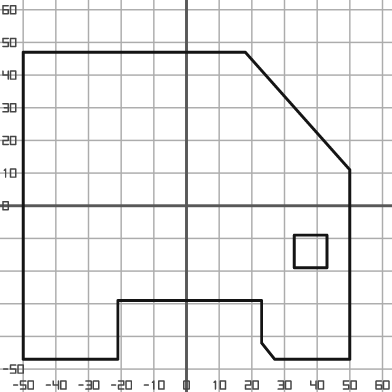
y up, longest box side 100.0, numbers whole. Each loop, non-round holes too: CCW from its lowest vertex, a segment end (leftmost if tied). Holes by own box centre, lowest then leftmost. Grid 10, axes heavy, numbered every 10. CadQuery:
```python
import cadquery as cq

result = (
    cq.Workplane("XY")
    .moveTo(-50.0, -47.0)
    .lineTo(-21.0, -47.0)
    .lineTo(-21.0, -29.0)
    .lineTo(23.0, -29.0)
    .lineTo(23.0, -42.0)
    .lineTo(27.0, -47.0)
    .lineTo(50.0, -47.0)
    .lineTo(50.0, 11.0)
    .lineTo(18.0, 47.0)
    .lineTo(-50.0, 47.0)
    .close()
    .moveTo(33.0, -19.0)
    .lineTo(43.0, -19.0)
    .lineTo(43.0, -9.0)
    .lineTo(33.0, -9.0)
    .close()
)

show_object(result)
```